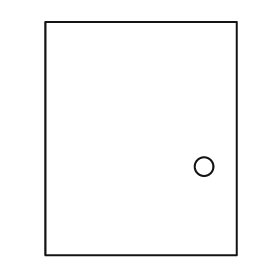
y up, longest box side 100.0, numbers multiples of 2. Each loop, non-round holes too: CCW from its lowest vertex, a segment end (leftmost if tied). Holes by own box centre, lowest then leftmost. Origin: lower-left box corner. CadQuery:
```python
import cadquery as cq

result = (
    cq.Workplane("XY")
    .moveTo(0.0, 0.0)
    .lineTo(82.0, 0.0)
    .lineTo(82.0, 100.0)
    .lineTo(0.0, 100.0)
    .close()
    .moveTo(68.0, 38.0)
    .circle(4.0)
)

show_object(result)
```